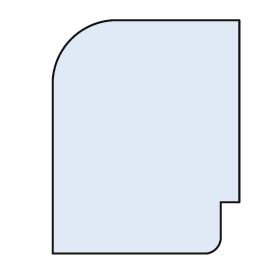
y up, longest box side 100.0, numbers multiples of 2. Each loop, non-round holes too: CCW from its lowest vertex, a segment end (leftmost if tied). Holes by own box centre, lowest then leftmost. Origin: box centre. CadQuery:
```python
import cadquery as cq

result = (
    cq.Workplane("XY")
    .moveTo(-40.0, -50.0)
    .lineTo(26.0, -50.0)
    .threePointArc((30.0, -48.0), (32.0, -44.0))
    .lineTo(32.0, -28.0)
    .lineTo(40.0, -28.0)
    .lineTo(40.0, 50.0)
    .lineTo(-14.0, 50.0)
    .threePointArc((-32.0, 42.0), (-40.0, 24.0))
    .close()
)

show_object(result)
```